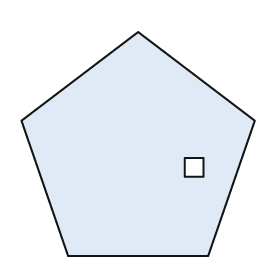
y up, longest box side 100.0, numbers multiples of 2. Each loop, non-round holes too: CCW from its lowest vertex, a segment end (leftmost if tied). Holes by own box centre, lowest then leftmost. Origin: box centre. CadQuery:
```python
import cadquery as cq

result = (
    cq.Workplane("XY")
    .moveTo(-30.0, -48.0)
    .lineTo(30.0, -48.0)
    .lineTo(50.0, 10.0)
    .lineTo(0.0, 48.0)
    .lineTo(-50.0, 10.0)
    .close()
    .moveTo(20.0, -14.0)
    .lineTo(28.0, -14.0)
    .lineTo(28.0, -6.0)
    .lineTo(20.0, -6.0)
    .close()
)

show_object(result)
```